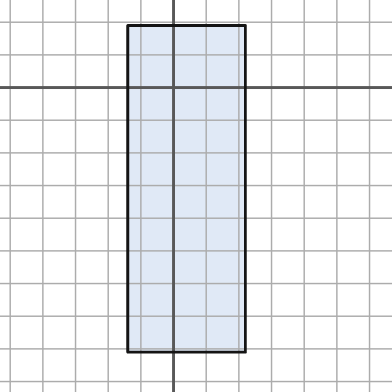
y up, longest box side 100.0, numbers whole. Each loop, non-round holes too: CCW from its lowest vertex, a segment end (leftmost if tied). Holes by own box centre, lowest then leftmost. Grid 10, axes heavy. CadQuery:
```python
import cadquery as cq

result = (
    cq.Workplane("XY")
    .moveTo(-14.0, -81.0)
    .lineTo(22.0, -81.0)
    .lineTo(22.0, 19.0)
    .lineTo(-14.0, 19.0)
    .close()
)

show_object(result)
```